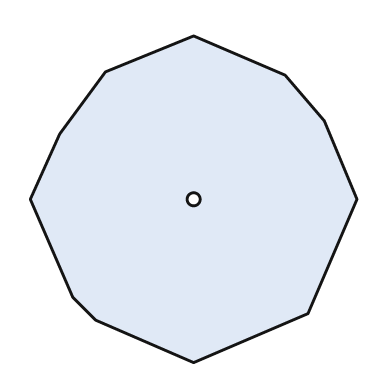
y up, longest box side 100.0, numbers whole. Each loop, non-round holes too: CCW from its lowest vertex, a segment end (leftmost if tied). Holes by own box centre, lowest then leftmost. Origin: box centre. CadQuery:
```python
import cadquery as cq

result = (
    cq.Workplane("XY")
    .moveTo(0.0, -50.0)
    .lineTo(35.0, -35.0)
    .lineTo(50.0, 0.0)
    .lineTo(40.0, 24.0)
    .lineTo(28.0, 38.0)
    .lineTo(0.0, 50.0)
    .lineTo(-27.0, 39.0)
    .lineTo(-41.0, 20.0)
    .lineTo(-50.0, 0.0)
    .lineTo(-37.0, -30.0)
    .lineTo(-30.0, -37.0)
    .close()
    .moveTo(0.0, 0.0)
    .circle(2.0)
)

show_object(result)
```